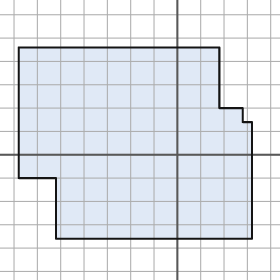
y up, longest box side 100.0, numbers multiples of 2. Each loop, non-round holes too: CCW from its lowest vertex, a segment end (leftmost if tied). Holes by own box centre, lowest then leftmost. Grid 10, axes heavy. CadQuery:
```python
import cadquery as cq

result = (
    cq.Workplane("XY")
    .moveTo(-52.0, -36.0)
    .lineTo(32.0, -36.0)
    .lineTo(32.0, 14.0)
    .lineTo(28.0, 14.0)
    .lineTo(28.0, 20.0)
    .lineTo(18.0, 20.0)
    .lineTo(18.0, 46.0)
    .lineTo(-68.0, 46.0)
    .lineTo(-68.0, -10.0)
    .lineTo(-52.0, -10.0)
    .close()
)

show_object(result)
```